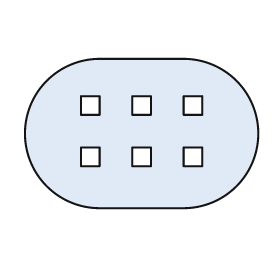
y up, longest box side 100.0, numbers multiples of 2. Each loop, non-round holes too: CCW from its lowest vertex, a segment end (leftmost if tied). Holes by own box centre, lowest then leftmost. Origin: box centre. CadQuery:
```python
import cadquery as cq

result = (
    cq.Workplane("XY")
    .moveTo(-18.0, -32.0)
    .lineTo(18.0, -32.0)
    .threePointArc((50.0, 0.0), (18.0, 32.0))
    .lineTo(-18.0, 32.0)
    .threePointArc((-50.0, 0.0), (-18.0, -32.0))
    .close()
    .moveTo(-26.0, -14.0)
    .lineTo(-18.0, -14.0)
    .lineTo(-18.0, -6.0)
    .lineTo(-26.0, -6.0)
    .close()
    .moveTo(-4.0, -14.0)
    .lineTo(4.0, -14.0)
    .lineTo(4.0, -6.0)
    .lineTo(-4.0, -6.0)
    .close()
    .moveTo(18.0, -14.0)
    .lineTo(26.0, -14.0)
    .lineTo(26.0, -6.0)
    .lineTo(18.0, -6.0)
    .close()
    .moveTo(-26.0, 8.0)
    .lineTo(-18.0, 8.0)
    .lineTo(-18.0, 16.0)
    .lineTo(-26.0, 16.0)
    .close()
    .moveTo(-4.0, 8.0)
    .lineTo(4.0, 8.0)
    .lineTo(4.0, 16.0)
    .lineTo(-4.0, 16.0)
    .close()
    .moveTo(18.0, 8.0)
    .lineTo(26.0, 8.0)
    .lineTo(26.0, 16.0)
    .lineTo(18.0, 16.0)
    .close()
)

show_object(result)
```